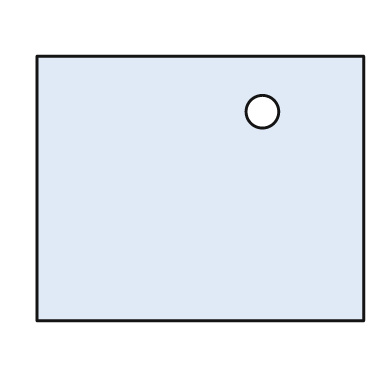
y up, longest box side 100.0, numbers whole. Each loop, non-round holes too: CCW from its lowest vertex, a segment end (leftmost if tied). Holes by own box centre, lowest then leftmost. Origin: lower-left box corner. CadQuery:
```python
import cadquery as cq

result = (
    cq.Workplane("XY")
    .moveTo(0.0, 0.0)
    .lineTo(100.0, 0.0)
    .lineTo(100.0, 81.0)
    .lineTo(0.0, 81.0)
    .close()
    .moveTo(69.0, 64.0)
    .circle(5.0)
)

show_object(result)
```